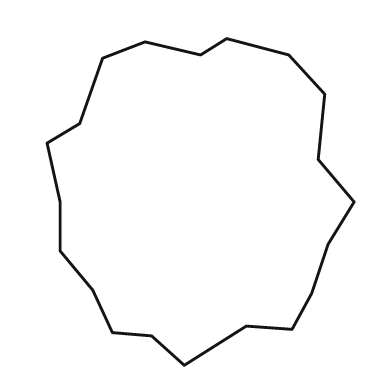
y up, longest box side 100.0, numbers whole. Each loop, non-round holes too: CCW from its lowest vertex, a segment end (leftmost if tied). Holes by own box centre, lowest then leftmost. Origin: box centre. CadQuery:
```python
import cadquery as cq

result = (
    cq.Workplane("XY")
    .moveTo(-5.0, -50.0)
    .lineTo(14.0, -38.0)
    .lineTo(28.0, -39.0)
    .lineTo(34.0, -28.0)
    .lineTo(39.0, -13.0)
    .lineTo(47.0, 0.0)
    .lineTo(36.0, 13.0)
    .lineTo(38.0, 33.0)
    .lineTo(27.0, 45.0)
    .lineTo(8.0, 50.0)
    .lineTo(0.0, 45.0)
    .lineTo(-17.0, 49.0)
    .lineTo(-30.0, 44.0)
    .lineTo(-37.0, 24.0)
    .lineTo(-47.0, 18.0)
    .lineTo(-43.0, 0.0)
    .lineTo(-43.0, -15.0)
    .lineTo(-33.0, -27.0)
    .lineTo(-27.0, -40.0)
    .lineTo(-15.0, -41.0)
    .close()
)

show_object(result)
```